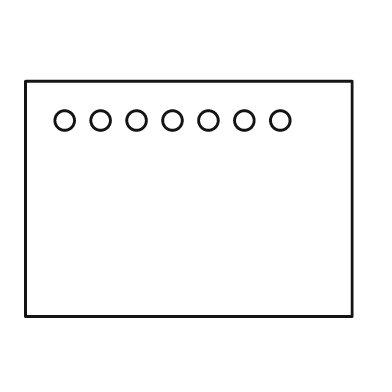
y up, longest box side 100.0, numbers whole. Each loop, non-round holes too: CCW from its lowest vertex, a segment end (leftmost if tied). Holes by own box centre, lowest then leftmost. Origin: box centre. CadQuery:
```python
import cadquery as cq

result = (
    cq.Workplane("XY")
    .moveTo(-50.0, -36.0)
    .lineTo(50.0, -36.0)
    .lineTo(50.0, 36.0)
    .lineTo(-50.0, 36.0)
    .close()
    .moveTo(-38.0, 24.0)
    .circle(3.0)
    .moveTo(-27.0, 24.0)
    .circle(3.0)
    .moveTo(-16.0, 24.0)
    .circle(3.0)
    .moveTo(-5.0, 24.0)
    .circle(3.0)
    .moveTo(6.0, 24.0)
    .circle(3.0)
    .moveTo(17.0, 24.0)
    .circle(3.0)
    .moveTo(28.0, 24.0)
    .circle(3.0)
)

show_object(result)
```